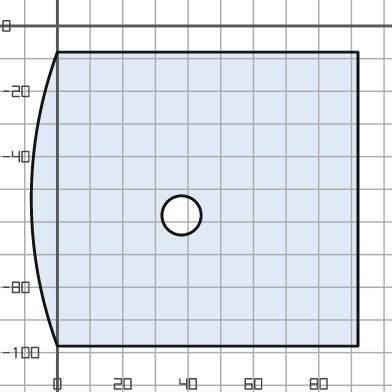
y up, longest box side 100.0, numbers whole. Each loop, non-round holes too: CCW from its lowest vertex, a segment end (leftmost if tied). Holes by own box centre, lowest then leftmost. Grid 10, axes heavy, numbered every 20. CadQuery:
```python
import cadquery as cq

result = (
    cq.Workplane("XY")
    .moveTo(0.0, -98.0)
    .lineTo(92.0, -98.0)
    .lineTo(92.0, -8.0)
    .lineTo(0.0, -8.0)
    .threePointArc((-8.0, -53.0), (0.0, -98.0))
    .close()
    .moveTo(38.0, -58.0)
    .circle(6.0)
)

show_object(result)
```